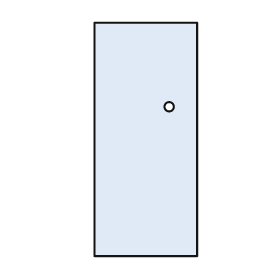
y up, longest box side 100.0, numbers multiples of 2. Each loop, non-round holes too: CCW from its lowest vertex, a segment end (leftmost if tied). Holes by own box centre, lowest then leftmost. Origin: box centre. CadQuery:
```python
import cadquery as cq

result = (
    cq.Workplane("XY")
    .moveTo(-22.0, -50.0)
    .lineTo(22.0, -50.0)
    .lineTo(22.0, 50.0)
    .lineTo(-22.0, 50.0)
    .close()
    .moveTo(10.0, 14.0)
    .circle(2.0)
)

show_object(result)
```